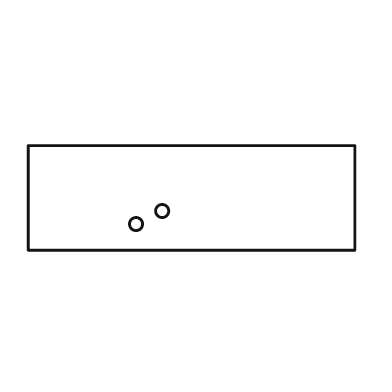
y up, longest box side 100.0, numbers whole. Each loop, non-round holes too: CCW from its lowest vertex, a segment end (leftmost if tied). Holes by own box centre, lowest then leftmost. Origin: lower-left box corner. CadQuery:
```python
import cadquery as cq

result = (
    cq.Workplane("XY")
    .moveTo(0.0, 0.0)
    .lineTo(100.0, 0.0)
    .lineTo(100.0, 32.0)
    .lineTo(0.0, 32.0)
    .close()
    .moveTo(33.0, 8.0)
    .circle(2.0)
    .moveTo(41.0, 12.0)
    .circle(2.0)
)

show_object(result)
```